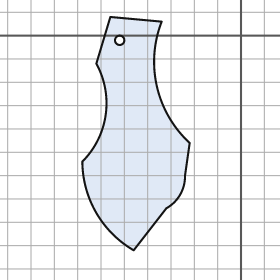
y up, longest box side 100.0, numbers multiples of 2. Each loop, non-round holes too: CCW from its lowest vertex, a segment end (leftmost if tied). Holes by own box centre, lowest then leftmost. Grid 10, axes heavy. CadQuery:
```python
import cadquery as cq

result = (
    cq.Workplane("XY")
    .moveTo(-46.0, -92.0)
    .lineTo(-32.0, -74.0)
    .threePointArc((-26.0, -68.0), (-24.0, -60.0))
    .lineTo(-22.0, -46.0)
    .threePointArc((-36.0, -22.0), (-34.0, 6.0))
    .lineTo(-56.0, 8.0)
    .lineTo(-62.0, -12.0)
    .threePointArc((-58.0, -34.0), (-68.0, -54.0))
    .threePointArc((-62.0, -76.0), (-46.0, -92.0))
    .close()
    .moveTo(-52.0, -2.0)
    .circle(2.0)
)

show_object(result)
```